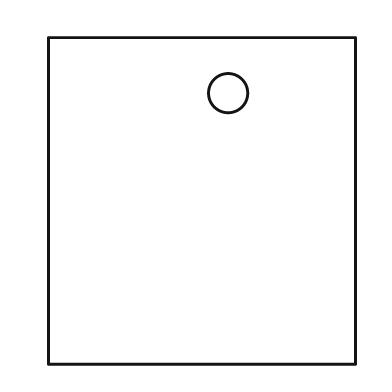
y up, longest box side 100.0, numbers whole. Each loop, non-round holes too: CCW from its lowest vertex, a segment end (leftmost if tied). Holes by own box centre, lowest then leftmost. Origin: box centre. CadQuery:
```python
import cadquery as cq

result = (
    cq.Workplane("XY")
    .moveTo(-47.0, -50.0)
    .lineTo(47.0, -50.0)
    .lineTo(47.0, 50.0)
    .lineTo(-47.0, 50.0)
    .close()
    .moveTo(8.0, 33.0)
    .circle(6.0)
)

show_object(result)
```